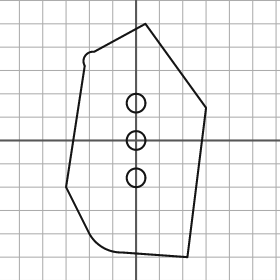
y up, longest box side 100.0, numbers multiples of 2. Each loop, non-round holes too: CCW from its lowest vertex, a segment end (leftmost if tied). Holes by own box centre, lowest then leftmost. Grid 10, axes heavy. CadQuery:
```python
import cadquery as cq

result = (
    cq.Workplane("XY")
    .moveTo(22.0, -50.0)
    .lineTo(30.0, 14.0)
    .lineTo(4.0, 50.0)
    .lineTo(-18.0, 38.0)
    .threePointArc((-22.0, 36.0), (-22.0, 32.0))
    .lineTo(-30.0, -20.0)
    .lineTo(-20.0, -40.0)
    .threePointArc((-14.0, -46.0), (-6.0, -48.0))
    .close()
    .moveTo(0.0, -16.0)
    .circle(4.0)
    .moveTo(0.0, 0.0)
    .circle(4.0)
    .moveTo(0.0, 16.0)
    .circle(4.0)
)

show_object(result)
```